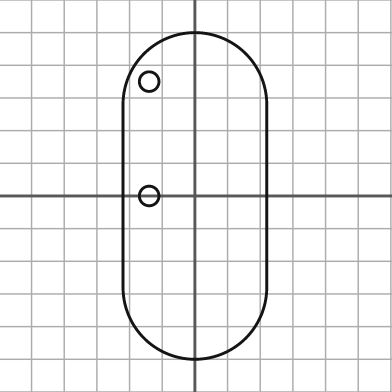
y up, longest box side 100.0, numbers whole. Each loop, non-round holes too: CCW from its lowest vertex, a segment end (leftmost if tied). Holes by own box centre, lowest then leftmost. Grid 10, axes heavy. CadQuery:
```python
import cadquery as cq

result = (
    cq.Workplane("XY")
    .moveTo(-22.0, -28.0)
    .threePointArc((0.0, -50.0), (22.0, -28.0))
    .lineTo(22.0, 28.0)
    .threePointArc((0.0, 50.0), (-22.0, 28.0))
    .close()
    .moveTo(-14.0, 0.0)
    .circle(3.0)
    .moveTo(-14.0, 35.0)
    .circle(3.0)
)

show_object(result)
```